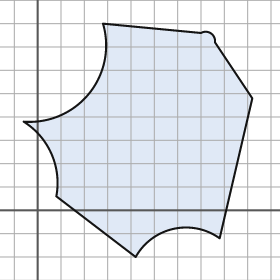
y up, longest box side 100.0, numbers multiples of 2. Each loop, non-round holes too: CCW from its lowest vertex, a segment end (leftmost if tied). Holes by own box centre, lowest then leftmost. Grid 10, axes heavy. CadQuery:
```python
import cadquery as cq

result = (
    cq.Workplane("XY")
    .moveTo(42.0, -20.0)
    .threePointArc((58.0, -8.0), (78.0, -12.0))
    .lineTo(92.0, 48.0)
    .lineTo(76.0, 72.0)
    .threePointArc((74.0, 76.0), (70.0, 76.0))
    .lineTo(28.0, 80.0)
    .threePointArc((22.0, 50.0), (-6.0, 38.0))
    .threePointArc((6.0, 24.0), (8.0, 6.0))
    .close()
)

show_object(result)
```